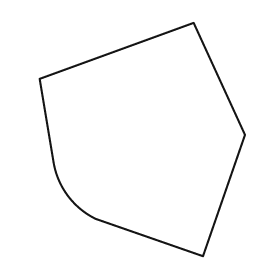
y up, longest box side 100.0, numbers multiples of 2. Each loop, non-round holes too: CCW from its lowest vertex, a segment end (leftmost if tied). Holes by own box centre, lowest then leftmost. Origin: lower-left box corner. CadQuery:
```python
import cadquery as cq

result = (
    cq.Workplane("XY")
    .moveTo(70.0, 0.0)
    .lineTo(88.0, 52.0)
    .lineTo(66.0, 100.0)
    .lineTo(0.0, 76.0)
    .lineTo(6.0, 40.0)
    .threePointArc((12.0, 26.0), (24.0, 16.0))
    .close()
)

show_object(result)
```